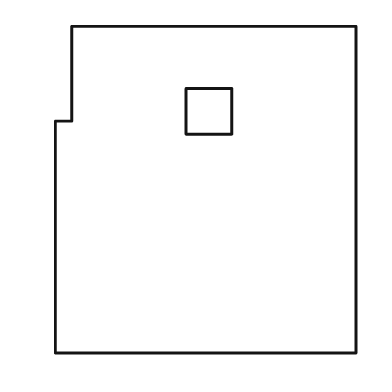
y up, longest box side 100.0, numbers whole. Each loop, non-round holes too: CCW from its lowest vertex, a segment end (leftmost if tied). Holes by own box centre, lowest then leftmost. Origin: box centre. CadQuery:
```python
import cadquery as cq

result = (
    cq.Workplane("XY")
    .moveTo(-46.0, -50.0)
    .lineTo(46.0, -50.0)
    .lineTo(46.0, 50.0)
    .lineTo(-41.0, 50.0)
    .lineTo(-41.0, 21.0)
    .lineTo(-46.0, 21.0)
    .close()
    .moveTo(-6.0, 17.0)
    .lineTo(8.0, 17.0)
    .lineTo(8.0, 31.0)
    .lineTo(-6.0, 31.0)
    .close()
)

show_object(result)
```